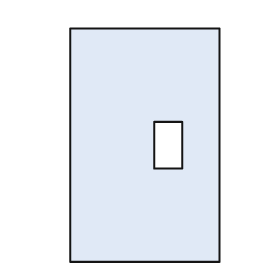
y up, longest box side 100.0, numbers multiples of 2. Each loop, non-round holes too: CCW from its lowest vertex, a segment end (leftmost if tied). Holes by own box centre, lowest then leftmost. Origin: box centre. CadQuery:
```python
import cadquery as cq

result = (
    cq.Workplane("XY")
    .moveTo(-32.0, -50.0)
    .lineTo(32.0, -50.0)
    .lineTo(32.0, 50.0)
    .lineTo(-32.0, 50.0)
    .close()
    .moveTo(4.0, -10.0)
    .lineTo(16.0, -10.0)
    .lineTo(16.0, 10.0)
    .lineTo(4.0, 10.0)
    .close()
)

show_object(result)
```